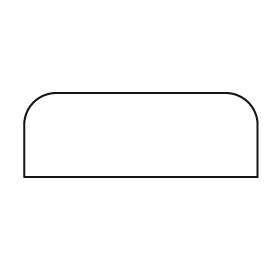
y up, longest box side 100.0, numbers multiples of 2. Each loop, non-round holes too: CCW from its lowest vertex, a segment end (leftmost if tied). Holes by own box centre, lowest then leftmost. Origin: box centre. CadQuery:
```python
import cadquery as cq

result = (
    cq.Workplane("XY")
    .moveTo(-50.0, -18.0)
    .lineTo(50.0, -18.0)
    .lineTo(50.0, 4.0)
    .threePointArc((46.0, 14.0), (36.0, 18.0))
    .lineTo(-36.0, 18.0)
    .threePointArc((-46.0, 14.0), (-50.0, 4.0))
    .close()
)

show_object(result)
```